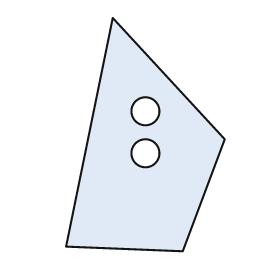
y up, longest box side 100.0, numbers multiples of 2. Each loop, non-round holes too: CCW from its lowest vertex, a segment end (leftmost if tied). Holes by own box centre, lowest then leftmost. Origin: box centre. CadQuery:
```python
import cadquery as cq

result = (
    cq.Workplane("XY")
    .moveTo(16.0, -50.0)
    .lineTo(34.0, -2.0)
    .lineTo(-14.0, 50.0)
    .lineTo(-34.0, -48.0)
    .close()
    .moveTo(0.0, -8.0)
    .circle(6.0)
    .moveTo(0.0, 10.0)
    .circle(6.0)
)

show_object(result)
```